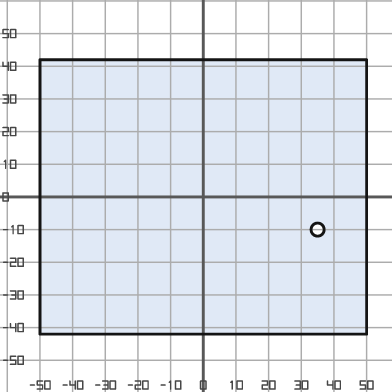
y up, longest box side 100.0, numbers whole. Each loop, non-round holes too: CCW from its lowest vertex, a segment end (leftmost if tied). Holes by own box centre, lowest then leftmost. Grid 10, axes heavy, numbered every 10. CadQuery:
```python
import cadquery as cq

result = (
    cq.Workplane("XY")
    .moveTo(-50.0, -42.0)
    .lineTo(50.0, -42.0)
    .lineTo(50.0, 42.0)
    .lineTo(-50.0, 42.0)
    .close()
    .moveTo(35.0, -10.0)
    .circle(2.0)
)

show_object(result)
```